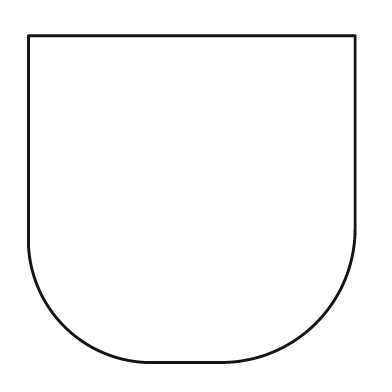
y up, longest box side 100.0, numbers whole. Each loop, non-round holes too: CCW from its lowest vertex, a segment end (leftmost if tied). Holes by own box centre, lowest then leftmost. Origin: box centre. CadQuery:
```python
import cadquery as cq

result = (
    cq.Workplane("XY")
    .moveTo(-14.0, -50.0)
    .lineTo(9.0, -50.0)
    .threePointArc((38.0, -38.0), (50.0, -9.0))
    .lineTo(50.0, 50.0)
    .lineTo(-50.0, 50.0)
    .lineTo(-50.0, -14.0)
    .threePointArc((-39.0, -39.0), (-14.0, -50.0))
    .close()
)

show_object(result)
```